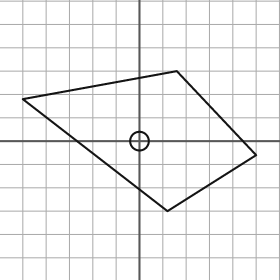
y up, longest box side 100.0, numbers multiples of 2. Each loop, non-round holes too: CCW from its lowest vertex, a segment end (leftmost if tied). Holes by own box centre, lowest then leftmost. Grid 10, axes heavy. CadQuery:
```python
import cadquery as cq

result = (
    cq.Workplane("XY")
    .moveTo(12.0, -30.0)
    .lineTo(50.0, -6.0)
    .lineTo(16.0, 30.0)
    .lineTo(-50.0, 18.0)
    .close()
    .moveTo(0.0, 0.0)
    .circle(4.0)
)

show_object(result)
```